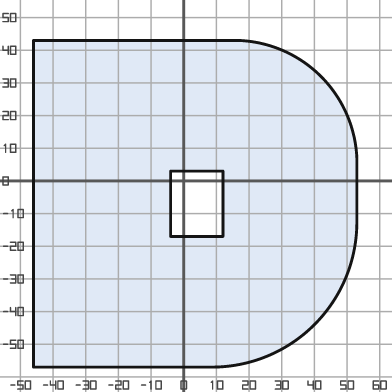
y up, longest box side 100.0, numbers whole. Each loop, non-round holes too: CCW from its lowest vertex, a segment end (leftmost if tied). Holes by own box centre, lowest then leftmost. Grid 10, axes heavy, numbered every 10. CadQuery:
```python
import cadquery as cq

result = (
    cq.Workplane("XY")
    .moveTo(-46.0, -57.0)
    .lineTo(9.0, -57.0)
    .threePointArc((40.0, -44.0), (53.0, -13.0))
    .lineTo(53.0, 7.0)
    .threePointArc((42.0, 32.0), (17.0, 43.0))
    .lineTo(-46.0, 43.0)
    .close()
    .moveTo(-4.0, -17.0)
    .lineTo(12.0, -17.0)
    .lineTo(12.0, 3.0)
    .lineTo(-4.0, 3.0)
    .close()
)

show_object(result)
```